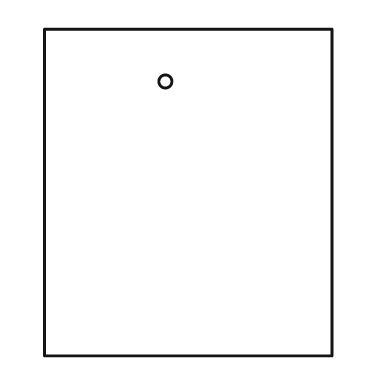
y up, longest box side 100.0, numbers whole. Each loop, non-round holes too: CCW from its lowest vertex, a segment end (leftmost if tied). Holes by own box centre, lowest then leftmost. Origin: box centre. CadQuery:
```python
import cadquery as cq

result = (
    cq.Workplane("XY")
    .moveTo(-44.0, -50.0)
    .lineTo(44.0, -50.0)
    .lineTo(44.0, 50.0)
    .lineTo(-44.0, 50.0)
    .close()
    .moveTo(-7.0, 34.0)
    .circle(2.0)
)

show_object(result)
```